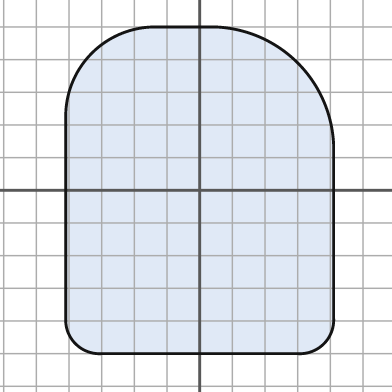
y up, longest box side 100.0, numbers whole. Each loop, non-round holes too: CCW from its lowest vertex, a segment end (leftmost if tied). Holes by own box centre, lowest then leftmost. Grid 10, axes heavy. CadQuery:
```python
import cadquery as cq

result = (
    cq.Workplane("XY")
    .moveTo(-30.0, -50.0)
    .lineTo(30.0, -50.0)
    .threePointArc((38.0, -47.0), (41.0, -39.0))
    .lineTo(41.0, 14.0)
    .threePointArc((30.0, 39.0), (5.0, 50.0))
    .lineTo(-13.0, 50.0)
    .threePointArc((-33.0, 42.0), (-41.0, 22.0))
    .lineTo(-41.0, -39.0)
    .threePointArc((-38.0, -47.0), (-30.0, -50.0))
    .close()
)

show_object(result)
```